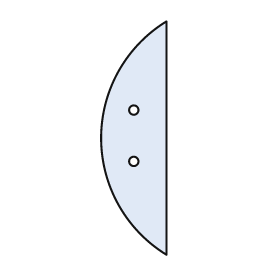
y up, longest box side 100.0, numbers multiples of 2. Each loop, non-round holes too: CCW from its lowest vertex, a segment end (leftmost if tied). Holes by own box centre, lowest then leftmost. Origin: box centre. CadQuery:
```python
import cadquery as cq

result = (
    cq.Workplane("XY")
    .moveTo(14.0, -50.0)
    .lineTo(14.0, 50.0)
    .threePointArc((-14.0, 0.0), (14.0, -50.0))
    .close()
    .moveTo(0.0, -10.0)
    .circle(2.0)
    .moveTo(0.0, 12.0)
    .circle(2.0)
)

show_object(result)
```